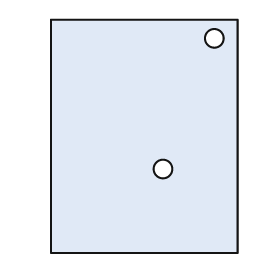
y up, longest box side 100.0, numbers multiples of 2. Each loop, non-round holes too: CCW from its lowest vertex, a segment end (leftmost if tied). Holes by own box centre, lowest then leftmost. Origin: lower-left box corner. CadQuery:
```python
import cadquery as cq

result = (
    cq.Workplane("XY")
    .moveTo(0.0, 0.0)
    .lineTo(80.0, 0.0)
    .lineTo(80.0, 100.0)
    .lineTo(0.0, 100.0)
    .close()
    .moveTo(48.0, 36.0)
    .circle(4.0)
    .moveTo(70.0, 92.0)
    .circle(4.0)
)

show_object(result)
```